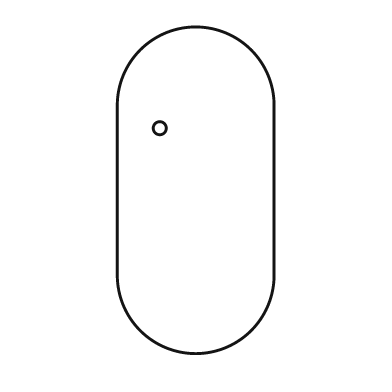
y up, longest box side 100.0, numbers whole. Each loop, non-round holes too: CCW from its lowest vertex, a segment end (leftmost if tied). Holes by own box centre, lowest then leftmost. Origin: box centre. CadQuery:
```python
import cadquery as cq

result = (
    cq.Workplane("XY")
    .moveTo(-24.0, -26.0)
    .threePointArc((0.0, -50.0), (24.0, -26.0))
    .lineTo(24.0, 26.0)
    .threePointArc((0.0, 50.0), (-24.0, 26.0))
    .close()
    .moveTo(-11.0, 19.0)
    .circle(2.0)
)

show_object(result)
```